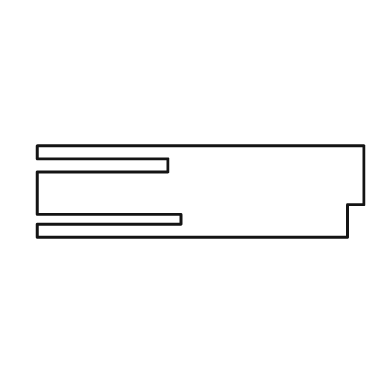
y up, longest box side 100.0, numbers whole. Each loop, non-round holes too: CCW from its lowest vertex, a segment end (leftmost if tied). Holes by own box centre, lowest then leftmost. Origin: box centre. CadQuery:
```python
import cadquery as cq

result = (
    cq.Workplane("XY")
    .moveTo(-50.0, -14.0)
    .lineTo(45.0, -14.0)
    .lineTo(45.0, -4.0)
    .lineTo(50.0, -4.0)
    .lineTo(50.0, 14.0)
    .lineTo(-50.0, 14.0)
    .lineTo(-50.0, 10.0)
    .lineTo(-10.0, 10.0)
    .lineTo(-10.0, 6.0)
    .lineTo(-50.0, 6.0)
    .lineTo(-50.0, -7.0)
    .lineTo(-6.0, -7.0)
    .lineTo(-6.0, -10.0)
    .lineTo(-50.0, -10.0)
    .close()
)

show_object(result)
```